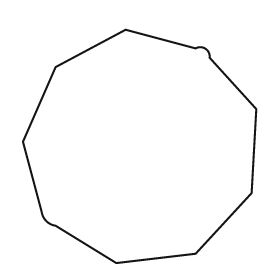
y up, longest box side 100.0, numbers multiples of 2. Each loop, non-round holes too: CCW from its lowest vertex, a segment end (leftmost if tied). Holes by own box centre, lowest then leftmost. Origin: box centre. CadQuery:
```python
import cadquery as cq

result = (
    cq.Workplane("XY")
    .moveTo(-10.0, -50.0)
    .lineTo(24.0, -46.0)
    .lineTo(48.0, -20.0)
    .lineTo(50.0, 16.0)
    .lineTo(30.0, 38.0)
    .threePointArc((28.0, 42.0), (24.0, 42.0))
    .lineTo(-6.0, 50.0)
    .lineTo(-36.0, 34.0)
    .lineTo(-50.0, 2.0)
    .lineTo(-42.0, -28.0)
    .threePointArc((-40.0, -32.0), (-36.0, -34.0))
    .close()
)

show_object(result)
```